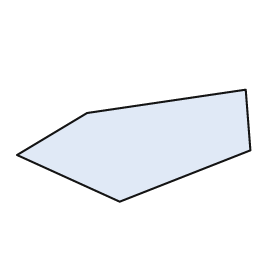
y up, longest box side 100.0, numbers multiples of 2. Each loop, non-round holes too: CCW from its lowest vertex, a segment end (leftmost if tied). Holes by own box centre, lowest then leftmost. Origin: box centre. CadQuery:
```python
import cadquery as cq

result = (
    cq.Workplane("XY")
    .moveTo(-6.0, -24.0)
    .lineTo(50.0, -2.0)
    .lineTo(48.0, 24.0)
    .lineTo(-20.0, 14.0)
    .lineTo(-50.0, -4.0)
    .close()
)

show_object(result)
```